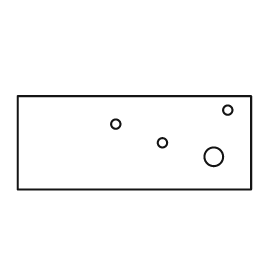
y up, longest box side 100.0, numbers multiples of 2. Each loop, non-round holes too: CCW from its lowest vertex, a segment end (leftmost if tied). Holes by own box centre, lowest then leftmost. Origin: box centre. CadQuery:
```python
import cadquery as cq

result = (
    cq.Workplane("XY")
    .moveTo(-50.0, -20.0)
    .lineTo(50.0, -20.0)
    .lineTo(50.0, 20.0)
    .lineTo(-50.0, 20.0)
    .close()
    .moveTo(34.0, -6.0)
    .circle(4.0)
    .moveTo(12.0, 0.0)
    .circle(2.0)
    .moveTo(-8.0, 8.0)
    .circle(2.0)
    .moveTo(40.0, 14.0)
    .circle(2.0)
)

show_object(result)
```